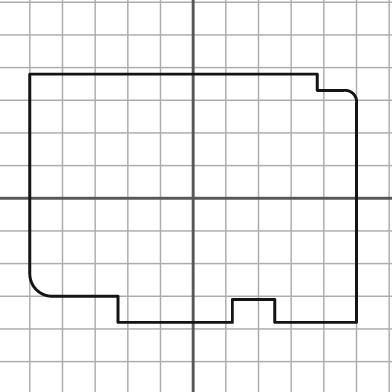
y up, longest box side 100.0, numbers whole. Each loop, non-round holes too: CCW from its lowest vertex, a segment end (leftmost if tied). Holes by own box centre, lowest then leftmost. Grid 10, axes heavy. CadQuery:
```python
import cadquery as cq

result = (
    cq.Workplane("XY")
    .moveTo(-23.0, -38.0)
    .lineTo(12.0, -38.0)
    .lineTo(12.0, -31.0)
    .lineTo(25.0, -31.0)
    .lineTo(25.0, -38.0)
    .lineTo(50.0, -38.0)
    .lineTo(50.0, 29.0)
    .threePointArc((49.0, 32.0), (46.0, 33.0))
    .lineTo(38.0, 33.0)
    .lineTo(38.0, 38.0)
    .lineTo(-50.0, 38.0)
    .lineTo(-50.0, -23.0)
    .threePointArc((-48.0, -28.0), (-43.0, -30.0))
    .lineTo(-23.0, -30.0)
    .close()
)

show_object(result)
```